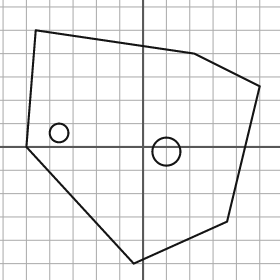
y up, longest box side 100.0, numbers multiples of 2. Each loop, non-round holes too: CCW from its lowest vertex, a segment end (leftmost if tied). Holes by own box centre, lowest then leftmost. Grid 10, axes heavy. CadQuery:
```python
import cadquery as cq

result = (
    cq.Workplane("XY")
    .moveTo(-4.0, -50.0)
    .lineTo(36.0, -32.0)
    .lineTo(50.0, 26.0)
    .lineTo(22.0, 40.0)
    .lineTo(-46.0, 50.0)
    .lineTo(-50.0, 0.0)
    .close()
    .moveTo(10.0, -2.0)
    .circle(6.0)
    .moveTo(-36.0, 6.0)
    .circle(4.0)
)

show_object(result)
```